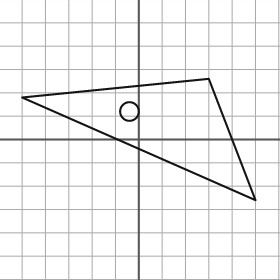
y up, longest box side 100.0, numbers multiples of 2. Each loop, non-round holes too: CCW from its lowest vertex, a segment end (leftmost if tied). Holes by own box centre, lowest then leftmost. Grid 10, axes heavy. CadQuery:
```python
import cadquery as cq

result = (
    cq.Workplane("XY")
    .moveTo(50.0, -26.0)
    .lineTo(30.0, 26.0)
    .lineTo(-50.0, 18.0)
    .close()
    .moveTo(-4.0, 12.0)
    .circle(4.0)
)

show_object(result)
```